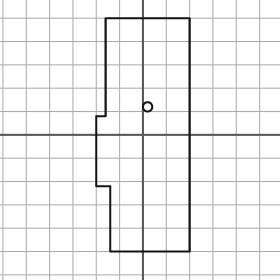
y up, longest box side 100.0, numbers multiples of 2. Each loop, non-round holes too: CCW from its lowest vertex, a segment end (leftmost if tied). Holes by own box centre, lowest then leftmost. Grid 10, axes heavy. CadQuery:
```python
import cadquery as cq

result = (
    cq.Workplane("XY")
    .moveTo(-14.0, -50.0)
    .lineTo(20.0, -50.0)
    .lineTo(20.0, 50.0)
    .lineTo(-16.0, 50.0)
    .lineTo(-16.0, 8.0)
    .lineTo(-20.0, 8.0)
    .lineTo(-20.0, -22.0)
    .lineTo(-14.0, -22.0)
    .close()
    .moveTo(2.0, 12.0)
    .circle(2.0)
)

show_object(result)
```